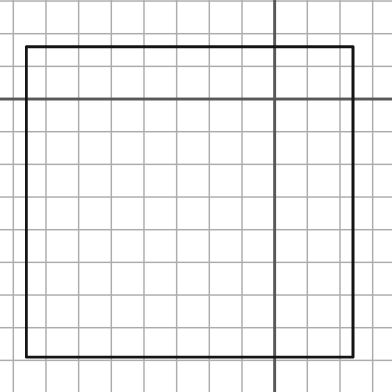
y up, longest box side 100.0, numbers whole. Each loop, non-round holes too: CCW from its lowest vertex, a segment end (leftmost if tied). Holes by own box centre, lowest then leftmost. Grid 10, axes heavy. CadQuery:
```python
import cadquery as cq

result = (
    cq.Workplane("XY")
    .moveTo(-76.0, -79.0)
    .lineTo(24.0, -79.0)
    .lineTo(24.0, 16.0)
    .lineTo(-76.0, 16.0)
    .close()
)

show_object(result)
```